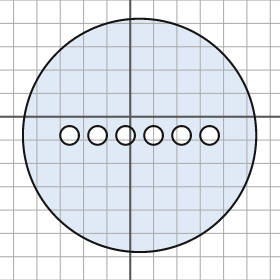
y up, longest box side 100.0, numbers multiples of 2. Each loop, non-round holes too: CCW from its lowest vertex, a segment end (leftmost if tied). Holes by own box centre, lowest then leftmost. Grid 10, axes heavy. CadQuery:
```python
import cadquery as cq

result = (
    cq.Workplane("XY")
    .moveTo(4.0, -8.0)
    .circle(50.0)
    .moveTo(-26.0, -8.0)
    .circle(4.0)
    .moveTo(-14.0, -8.0)
    .circle(4.0)
    .moveTo(-2.0, -8.0)
    .circle(4.0)
    .moveTo(10.0, -8.0)
    .circle(4.0)
    .moveTo(22.0, -8.0)
    .circle(4.0)
    .moveTo(34.0, -8.0)
    .circle(4.0)
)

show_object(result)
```